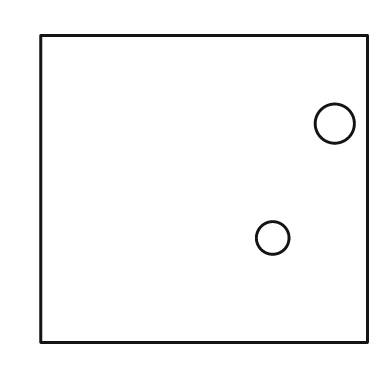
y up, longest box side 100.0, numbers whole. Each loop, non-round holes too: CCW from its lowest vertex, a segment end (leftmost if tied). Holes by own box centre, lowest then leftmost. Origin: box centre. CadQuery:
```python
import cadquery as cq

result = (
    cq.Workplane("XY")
    .moveTo(-50.0, -47.0)
    .lineTo(50.0, -47.0)
    .lineTo(50.0, 47.0)
    .lineTo(-50.0, 47.0)
    .close()
    .moveTo(21.0, -15.0)
    .circle(5.0)
    .moveTo(40.0, 20.0)
    .circle(6.0)
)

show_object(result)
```